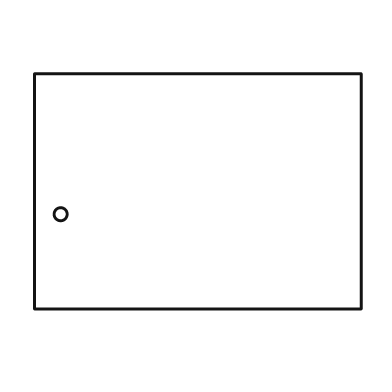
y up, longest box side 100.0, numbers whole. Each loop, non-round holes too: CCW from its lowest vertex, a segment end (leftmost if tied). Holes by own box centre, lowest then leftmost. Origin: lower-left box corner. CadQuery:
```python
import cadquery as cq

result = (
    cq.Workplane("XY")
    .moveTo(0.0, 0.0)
    .lineTo(100.0, 0.0)
    .lineTo(100.0, 72.0)
    .lineTo(0.0, 72.0)
    .close()
    .moveTo(8.0, 29.0)
    .circle(2.0)
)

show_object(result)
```